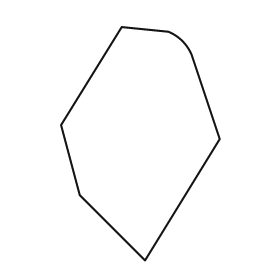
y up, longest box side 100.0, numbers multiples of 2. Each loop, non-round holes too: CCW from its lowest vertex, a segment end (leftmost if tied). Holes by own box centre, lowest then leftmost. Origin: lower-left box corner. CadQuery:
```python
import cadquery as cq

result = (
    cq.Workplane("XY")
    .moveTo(36.0, 0.0)
    .lineTo(68.0, 52.0)
    .lineTo(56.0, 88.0)
    .threePointArc((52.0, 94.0), (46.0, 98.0))
    .lineTo(26.0, 100.0)
    .lineTo(0.0, 58.0)
    .lineTo(8.0, 28.0)
    .close()
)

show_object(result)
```